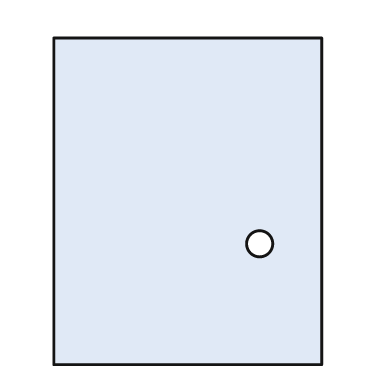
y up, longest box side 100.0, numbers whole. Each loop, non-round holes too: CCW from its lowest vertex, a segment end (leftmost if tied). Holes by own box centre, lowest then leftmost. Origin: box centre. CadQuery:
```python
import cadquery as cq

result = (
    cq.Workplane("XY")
    .moveTo(-41.0, -50.0)
    .lineTo(41.0, -50.0)
    .lineTo(41.0, 50.0)
    .lineTo(-41.0, 50.0)
    .close()
    .moveTo(22.0, -13.0)
    .circle(4.0)
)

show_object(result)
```